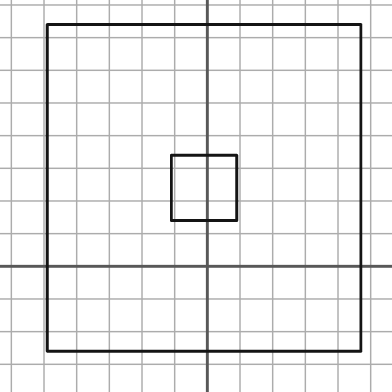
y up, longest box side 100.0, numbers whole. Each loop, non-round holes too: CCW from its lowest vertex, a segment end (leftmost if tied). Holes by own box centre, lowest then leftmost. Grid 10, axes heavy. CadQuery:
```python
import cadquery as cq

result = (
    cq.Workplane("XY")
    .moveTo(-49.0, -26.0)
    .lineTo(47.0, -26.0)
    .lineTo(47.0, 74.0)
    .lineTo(-49.0, 74.0)
    .close()
    .moveTo(-11.0, 14.0)
    .lineTo(9.0, 14.0)
    .lineTo(9.0, 34.0)
    .lineTo(-11.0, 34.0)
    .close()
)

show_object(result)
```